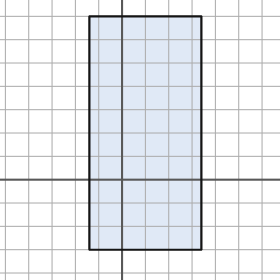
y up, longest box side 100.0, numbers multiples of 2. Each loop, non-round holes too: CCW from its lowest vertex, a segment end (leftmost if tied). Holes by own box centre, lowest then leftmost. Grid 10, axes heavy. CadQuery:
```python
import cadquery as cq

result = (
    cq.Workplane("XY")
    .moveTo(-14.0, -30.0)
    .lineTo(34.0, -30.0)
    .lineTo(34.0, 70.0)
    .lineTo(-14.0, 70.0)
    .close()
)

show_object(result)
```